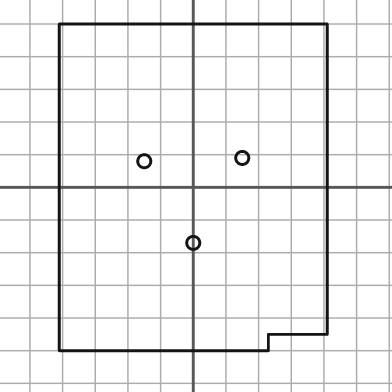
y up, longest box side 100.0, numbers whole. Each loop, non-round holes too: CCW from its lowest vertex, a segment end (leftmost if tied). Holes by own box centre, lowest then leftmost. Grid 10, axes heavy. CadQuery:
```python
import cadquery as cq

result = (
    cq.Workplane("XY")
    .moveTo(-41.0, -50.0)
    .lineTo(23.0, -50.0)
    .lineTo(23.0, -45.0)
    .lineTo(41.0, -45.0)
    .lineTo(41.0, 50.0)
    .lineTo(-41.0, 50.0)
    .close()
    .moveTo(0.0, -17.0)
    .circle(2.0)
    .moveTo(-15.0, 8.0)
    .circle(2.0)
    .moveTo(15.0, 9.0)
    .circle(2.0)
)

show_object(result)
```